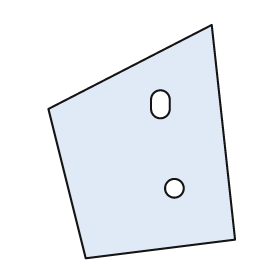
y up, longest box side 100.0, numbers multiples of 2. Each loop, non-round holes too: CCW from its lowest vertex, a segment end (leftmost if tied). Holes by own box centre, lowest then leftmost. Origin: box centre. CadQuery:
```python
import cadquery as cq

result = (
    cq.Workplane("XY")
    .moveTo(-24.0, -50.0)
    .lineTo(40.0, -42.0)
    .lineTo(30.0, 50.0)
    .lineTo(-40.0, 14.0)
    .close()
    .moveTo(14.0, -20.0)
    .circle(4.0)
    .moveTo(4.0, 14.0)
    .threePointArc((8.0, 10.0), (12.0, 14.0))
    .lineTo(12.0, 18.0)
    .threePointArc((8.0, 22.0), (4.0, 18.0))
    .close()
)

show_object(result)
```